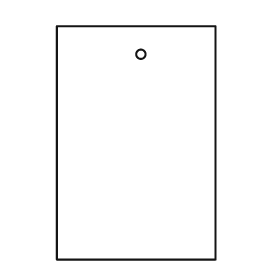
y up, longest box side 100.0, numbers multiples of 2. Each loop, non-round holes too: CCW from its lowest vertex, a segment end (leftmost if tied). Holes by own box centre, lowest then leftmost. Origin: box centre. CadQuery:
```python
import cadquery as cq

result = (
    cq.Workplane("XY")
    .moveTo(-34.0, -50.0)
    .lineTo(34.0, -50.0)
    .lineTo(34.0, 50.0)
    .lineTo(-34.0, 50.0)
    .close()
    .moveTo(2.0, 38.0)
    .circle(2.0)
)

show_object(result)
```